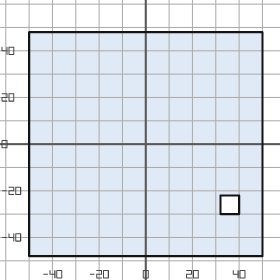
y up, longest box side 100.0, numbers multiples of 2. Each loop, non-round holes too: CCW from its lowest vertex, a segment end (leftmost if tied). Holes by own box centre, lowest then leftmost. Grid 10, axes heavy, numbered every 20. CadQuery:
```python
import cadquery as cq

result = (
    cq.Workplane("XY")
    .moveTo(-50.0, -48.0)
    .lineTo(50.0, -48.0)
    .lineTo(50.0, 48.0)
    .lineTo(-50.0, 48.0)
    .close()
    .moveTo(32.0, -30.0)
    .lineTo(40.0, -30.0)
    .lineTo(40.0, -22.0)
    .lineTo(32.0, -22.0)
    .close()
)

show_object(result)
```